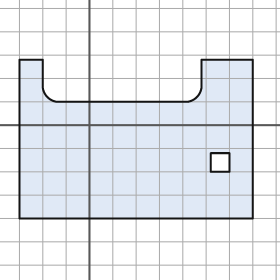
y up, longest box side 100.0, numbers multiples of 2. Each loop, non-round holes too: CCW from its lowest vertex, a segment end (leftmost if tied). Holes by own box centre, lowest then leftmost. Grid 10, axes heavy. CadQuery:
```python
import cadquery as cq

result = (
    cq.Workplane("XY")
    .moveTo(-30.0, -40.0)
    .lineTo(70.0, -40.0)
    .lineTo(70.0, 28.0)
    .lineTo(48.0, 28.0)
    .lineTo(48.0, 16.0)
    .threePointArc((46.0, 12.0), (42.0, 10.0))
    .lineTo(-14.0, 10.0)
    .threePointArc((-18.0, 12.0), (-20.0, 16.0))
    .lineTo(-20.0, 28.0)
    .lineTo(-30.0, 28.0)
    .close()
    .moveTo(52.0, -20.0)
    .lineTo(60.0, -20.0)
    .lineTo(60.0, -12.0)
    .lineTo(52.0, -12.0)
    .close()
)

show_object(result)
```